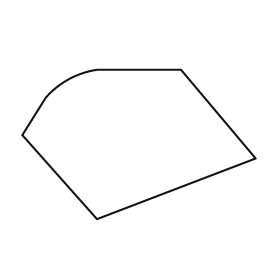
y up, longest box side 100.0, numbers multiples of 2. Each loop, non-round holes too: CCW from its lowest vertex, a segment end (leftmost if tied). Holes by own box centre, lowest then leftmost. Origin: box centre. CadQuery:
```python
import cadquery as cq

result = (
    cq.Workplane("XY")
    .moveTo(-18.0, -32.0)
    .lineTo(50.0, -6.0)
    .lineTo(18.0, 32.0)
    .lineTo(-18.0, 32.0)
    .threePointArc((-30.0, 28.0), (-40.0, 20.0))
    .lineTo(-50.0, 4.0)
    .close()
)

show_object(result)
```